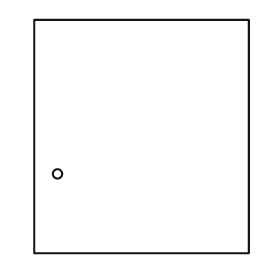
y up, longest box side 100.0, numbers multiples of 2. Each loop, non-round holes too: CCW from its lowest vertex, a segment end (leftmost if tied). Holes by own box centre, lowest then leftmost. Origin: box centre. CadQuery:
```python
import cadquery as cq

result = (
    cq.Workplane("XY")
    .moveTo(-46.0, -50.0)
    .lineTo(46.0, -50.0)
    .lineTo(46.0, 50.0)
    .lineTo(-46.0, 50.0)
    .close()
    .moveTo(-36.0, -16.0)
    .circle(2.0)
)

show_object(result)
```